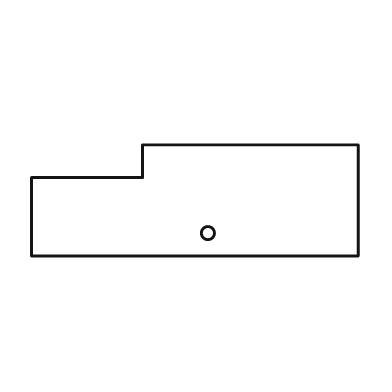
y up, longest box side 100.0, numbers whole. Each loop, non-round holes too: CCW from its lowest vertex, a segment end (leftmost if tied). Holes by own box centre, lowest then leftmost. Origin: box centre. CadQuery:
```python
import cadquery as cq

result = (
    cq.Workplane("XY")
    .moveTo(-50.0, -17.0)
    .lineTo(50.0, -17.0)
    .lineTo(50.0, 17.0)
    .lineTo(-16.0, 17.0)
    .lineTo(-16.0, 7.0)
    .lineTo(-50.0, 7.0)
    .close()
    .moveTo(4.0, -10.0)
    .circle(2.0)
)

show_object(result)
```